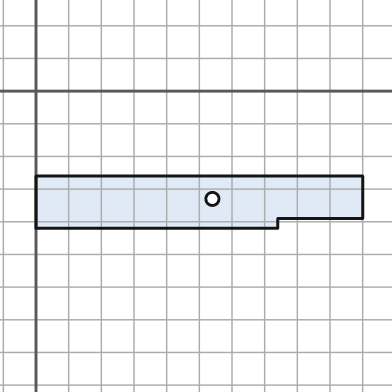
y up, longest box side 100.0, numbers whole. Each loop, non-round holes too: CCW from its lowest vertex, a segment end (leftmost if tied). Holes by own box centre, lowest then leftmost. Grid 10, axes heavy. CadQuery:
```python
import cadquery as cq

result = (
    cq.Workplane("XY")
    .moveTo(0.0, -42.0)
    .lineTo(74.0, -42.0)
    .lineTo(74.0, -39.0)
    .lineTo(100.0, -39.0)
    .lineTo(100.0, -26.0)
    .lineTo(0.0, -26.0)
    .close()
    .moveTo(54.0, -33.0)
    .circle(2.0)
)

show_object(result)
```